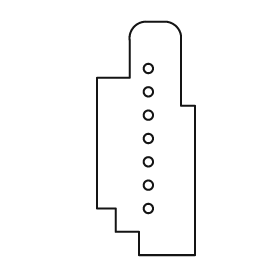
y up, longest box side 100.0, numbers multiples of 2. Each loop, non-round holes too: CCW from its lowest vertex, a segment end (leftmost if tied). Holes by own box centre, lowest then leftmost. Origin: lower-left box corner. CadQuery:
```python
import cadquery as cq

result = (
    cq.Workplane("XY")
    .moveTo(18.0, 0.0)
    .lineTo(42.0, 0.0)
    .lineTo(42.0, 64.0)
    .lineTo(36.0, 64.0)
    .lineTo(36.0, 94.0)
    .threePointArc((34.0, 98.0), (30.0, 100.0))
    .lineTo(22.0, 100.0)
    .threePointArc((16.0, 98.0), (14.0, 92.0))
    .lineTo(14.0, 76.0)
    .lineTo(0.0, 76.0)
    .lineTo(0.0, 20.0)
    .lineTo(8.0, 20.0)
    .lineTo(8.0, 10.0)
    .lineTo(18.0, 10.0)
    .close()
    .moveTo(22.0, 20.0)
    .circle(2.0)
    .moveTo(22.0, 30.0)
    .circle(2.0)
    .moveTo(22.0, 40.0)
    .circle(2.0)
    .moveTo(22.0, 50.0)
    .circle(2.0)
    .moveTo(22.0, 60.0)
    .circle(2.0)
    .moveTo(22.0, 70.0)
    .circle(2.0)
    .moveTo(22.0, 80.0)
    .circle(2.0)
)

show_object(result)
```